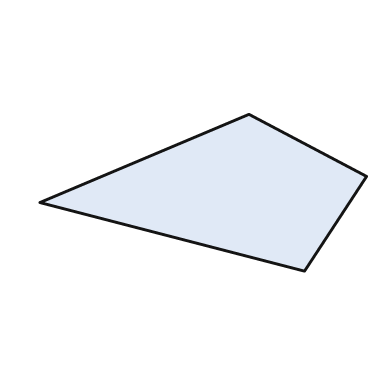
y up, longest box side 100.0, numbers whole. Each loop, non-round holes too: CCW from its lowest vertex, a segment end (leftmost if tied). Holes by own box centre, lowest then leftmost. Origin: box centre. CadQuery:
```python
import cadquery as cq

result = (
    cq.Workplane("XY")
    .moveTo(31.0, -24.0)
    .lineTo(50.0, 5.0)
    .lineTo(14.0, 24.0)
    .lineTo(-50.0, -3.0)
    .close()
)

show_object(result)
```